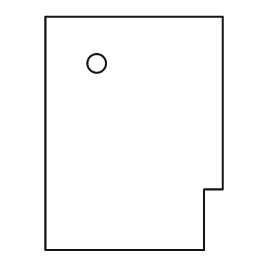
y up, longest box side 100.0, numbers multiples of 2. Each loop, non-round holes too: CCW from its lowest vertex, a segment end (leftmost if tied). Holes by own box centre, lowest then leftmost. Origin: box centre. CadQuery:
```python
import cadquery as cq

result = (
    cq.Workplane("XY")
    .moveTo(-38.0, -50.0)
    .lineTo(30.0, -50.0)
    .lineTo(30.0, -24.0)
    .lineTo(38.0, -24.0)
    .lineTo(38.0, 50.0)
    .lineTo(-38.0, 50.0)
    .close()
    .moveTo(-16.0, 30.0)
    .circle(4.0)
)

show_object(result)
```